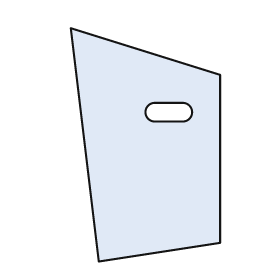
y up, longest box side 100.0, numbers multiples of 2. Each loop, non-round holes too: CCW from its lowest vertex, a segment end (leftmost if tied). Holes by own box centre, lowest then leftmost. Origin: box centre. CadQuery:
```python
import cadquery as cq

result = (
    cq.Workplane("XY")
    .moveTo(-20.0, -50.0)
    .lineTo(32.0, -42.0)
    .lineTo(32.0, 30.0)
    .lineTo(-32.0, 50.0)
    .close()
    .moveTo(4.0, 10.0)
    .lineTo(16.0, 10.0)
    .threePointArc((20.0, 14.0), (16.0, 18.0))
    .lineTo(4.0, 18.0)
    .threePointArc((0.0, 14.0), (4.0, 10.0))
    .close()
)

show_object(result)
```